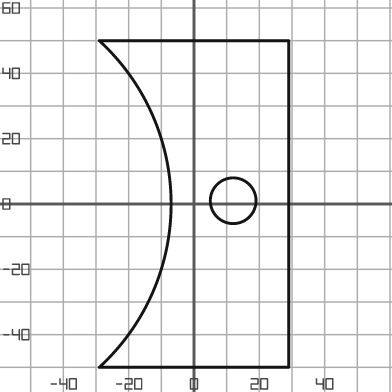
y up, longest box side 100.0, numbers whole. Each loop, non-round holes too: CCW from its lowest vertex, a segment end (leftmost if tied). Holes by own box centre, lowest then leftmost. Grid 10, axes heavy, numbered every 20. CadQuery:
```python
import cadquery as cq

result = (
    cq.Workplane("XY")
    .moveTo(-29.0, -50.0)
    .lineTo(29.0, -50.0)
    .lineTo(29.0, 50.0)
    .lineTo(-29.0, 50.0)
    .threePointArc((-7.0, 0.0), (-29.0, -50.0))
    .close()
    .moveTo(12.0, 1.0)
    .circle(7.0)
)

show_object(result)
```